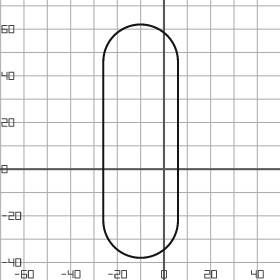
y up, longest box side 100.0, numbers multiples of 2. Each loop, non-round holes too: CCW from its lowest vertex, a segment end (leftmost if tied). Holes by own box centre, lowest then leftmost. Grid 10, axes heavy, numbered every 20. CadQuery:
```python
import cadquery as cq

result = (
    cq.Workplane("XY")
    .moveTo(-26.0, -22.0)
    .threePointArc((-10.0, -38.0), (6.0, -22.0))
    .lineTo(6.0, 46.0)
    .threePointArc((-10.0, 62.0), (-26.0, 46.0))
    .close()
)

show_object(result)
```